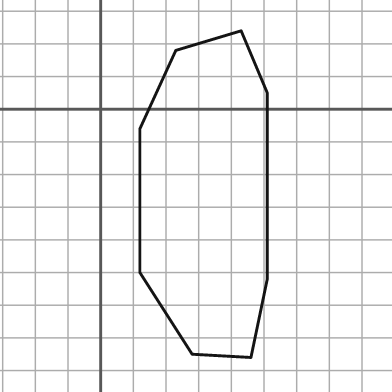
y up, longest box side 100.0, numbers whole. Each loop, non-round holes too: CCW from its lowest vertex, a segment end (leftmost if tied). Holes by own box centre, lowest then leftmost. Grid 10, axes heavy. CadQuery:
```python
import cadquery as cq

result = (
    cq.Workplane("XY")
    .moveTo(46.0, -76.0)
    .lineTo(51.0, -52.0)
    .lineTo(51.0, 5.0)
    .lineTo(43.0, 24.0)
    .lineTo(23.0, 18.0)
    .lineTo(12.0, -6.0)
    .lineTo(12.0, -50.0)
    .lineTo(28.0, -75.0)
    .close()
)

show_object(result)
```